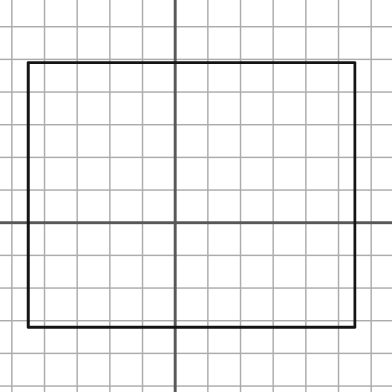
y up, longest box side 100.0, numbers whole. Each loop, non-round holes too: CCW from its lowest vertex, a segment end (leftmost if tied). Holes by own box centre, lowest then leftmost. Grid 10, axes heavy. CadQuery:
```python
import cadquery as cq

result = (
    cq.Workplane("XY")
    .moveTo(-45.0, -32.0)
    .lineTo(55.0, -32.0)
    .lineTo(55.0, 49.0)
    .lineTo(-45.0, 49.0)
    .close()
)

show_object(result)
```